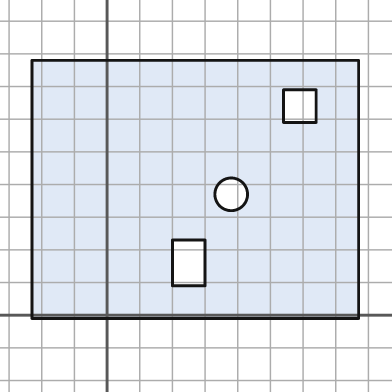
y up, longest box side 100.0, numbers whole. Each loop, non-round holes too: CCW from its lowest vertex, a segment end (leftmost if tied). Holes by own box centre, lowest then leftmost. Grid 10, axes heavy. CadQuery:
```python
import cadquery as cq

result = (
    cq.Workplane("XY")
    .moveTo(-23.0, -1.0)
    .lineTo(77.0, -1.0)
    .lineTo(77.0, 78.0)
    .lineTo(-23.0, 78.0)
    .close()
    .moveTo(20.0, 9.0)
    .lineTo(30.0, 9.0)
    .lineTo(30.0, 23.0)
    .lineTo(20.0, 23.0)
    .close()
    .moveTo(38.0, 37.0)
    .circle(5.0)
    .moveTo(54.0, 59.0)
    .lineTo(64.0, 59.0)
    .lineTo(64.0, 69.0)
    .lineTo(54.0, 69.0)
    .close()
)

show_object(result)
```